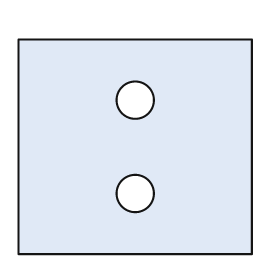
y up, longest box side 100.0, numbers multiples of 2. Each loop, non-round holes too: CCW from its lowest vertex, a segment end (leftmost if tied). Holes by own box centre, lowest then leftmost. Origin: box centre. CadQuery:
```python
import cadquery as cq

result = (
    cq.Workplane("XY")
    .moveTo(-50.0, -46.0)
    .lineTo(50.0, -46.0)
    .lineTo(50.0, 46.0)
    .lineTo(-50.0, 46.0)
    .close()
    .moveTo(0.0, -20.0)
    .circle(8.0)
    .moveTo(0.0, 20.0)
    .circle(8.0)
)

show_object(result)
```